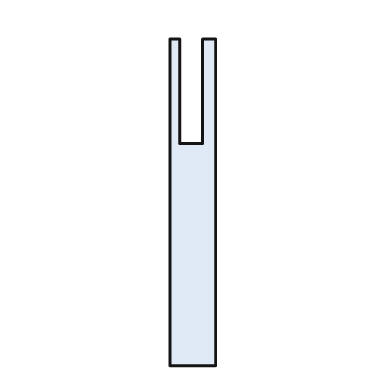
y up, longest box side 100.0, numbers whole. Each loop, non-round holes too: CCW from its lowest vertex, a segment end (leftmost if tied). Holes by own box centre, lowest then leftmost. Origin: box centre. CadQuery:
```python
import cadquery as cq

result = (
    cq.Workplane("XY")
    .moveTo(-7.0, -50.0)
    .lineTo(7.0, -50.0)
    .lineTo(7.0, 50.0)
    .lineTo(3.0, 50.0)
    .lineTo(3.0, 18.0)
    .lineTo(-4.0, 18.0)
    .lineTo(-4.0, 50.0)
    .lineTo(-7.0, 50.0)
    .close()
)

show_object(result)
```